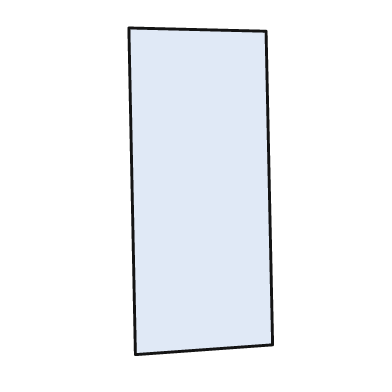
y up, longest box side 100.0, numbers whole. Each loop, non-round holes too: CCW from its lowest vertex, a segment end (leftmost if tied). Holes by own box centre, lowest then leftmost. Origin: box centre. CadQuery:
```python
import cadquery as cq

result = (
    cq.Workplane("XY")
    .moveTo(-20.0, -50.0)
    .lineTo(22.0, -47.0)
    .lineTo(20.0, 49.0)
    .lineTo(-22.0, 50.0)
    .close()
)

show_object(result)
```